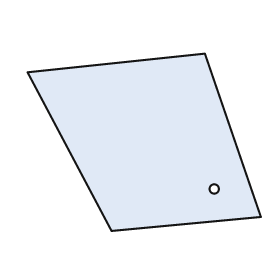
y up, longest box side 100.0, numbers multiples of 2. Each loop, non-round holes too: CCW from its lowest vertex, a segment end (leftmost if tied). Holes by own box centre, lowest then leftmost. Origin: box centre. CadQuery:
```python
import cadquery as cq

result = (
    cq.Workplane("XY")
    .moveTo(-14.0, -38.0)
    .lineTo(50.0, -32.0)
    .lineTo(26.0, 38.0)
    .lineTo(-50.0, 30.0)
    .close()
    .moveTo(30.0, -20.0)
    .circle(2.0)
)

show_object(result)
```